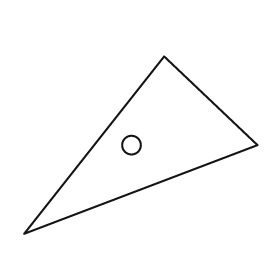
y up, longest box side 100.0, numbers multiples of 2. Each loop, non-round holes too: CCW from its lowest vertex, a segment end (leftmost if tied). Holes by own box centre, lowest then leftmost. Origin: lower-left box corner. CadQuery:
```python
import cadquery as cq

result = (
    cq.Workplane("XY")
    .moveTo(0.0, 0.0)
    .lineTo(100.0, 38.0)
    .lineTo(60.0, 76.0)
    .close()
    .moveTo(46.0, 38.0)
    .circle(4.0)
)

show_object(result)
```